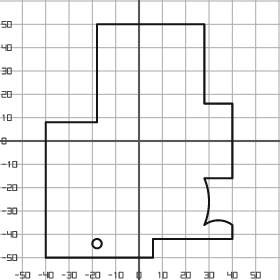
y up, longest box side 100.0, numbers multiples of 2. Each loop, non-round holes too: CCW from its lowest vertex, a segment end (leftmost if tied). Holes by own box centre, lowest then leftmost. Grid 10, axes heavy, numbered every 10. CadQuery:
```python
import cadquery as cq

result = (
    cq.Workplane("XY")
    .moveTo(-40.0, -50.0)
    .lineTo(6.0, -50.0)
    .lineTo(6.0, -42.0)
    .lineTo(40.0, -42.0)
    .lineTo(40.0, -36.0)
    .threePointArc((34.0, -34.0), (28.0, -36.0))
    .threePointArc((30.0, -26.0), (28.0, -16.0))
    .lineTo(40.0, -16.0)
    .lineTo(40.0, 16.0)
    .lineTo(28.0, 16.0)
    .lineTo(28.0, 50.0)
    .lineTo(-18.0, 50.0)
    .lineTo(-18.0, 8.0)
    .lineTo(-40.0, 8.0)
    .close()
    .moveTo(-18.0, -44.0)
    .circle(2.0)
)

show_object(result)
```